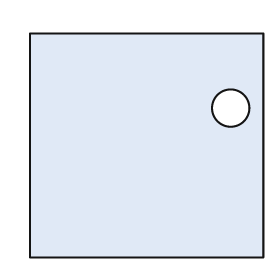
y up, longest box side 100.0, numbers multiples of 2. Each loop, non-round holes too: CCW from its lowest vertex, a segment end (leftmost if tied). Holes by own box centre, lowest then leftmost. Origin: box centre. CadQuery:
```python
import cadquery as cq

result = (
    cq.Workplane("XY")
    .moveTo(-50.0, -48.0)
    .lineTo(50.0, -48.0)
    .lineTo(50.0, 48.0)
    .lineTo(-50.0, 48.0)
    .close()
    .moveTo(36.0, 16.0)
    .circle(8.0)
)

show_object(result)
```